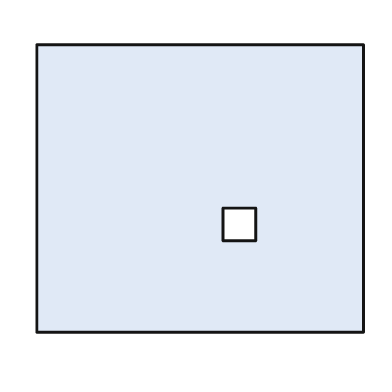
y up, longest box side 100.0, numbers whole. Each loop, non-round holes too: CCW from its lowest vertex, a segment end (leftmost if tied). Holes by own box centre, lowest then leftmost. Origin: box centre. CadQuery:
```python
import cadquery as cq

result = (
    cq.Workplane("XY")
    .moveTo(-50.0, -44.0)
    .lineTo(50.0, -44.0)
    .lineTo(50.0, 44.0)
    .lineTo(-50.0, 44.0)
    .close()
    .moveTo(7.0, -16.0)
    .lineTo(17.0, -16.0)
    .lineTo(17.0, -6.0)
    .lineTo(7.0, -6.0)
    .close()
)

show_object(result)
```